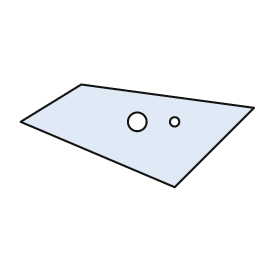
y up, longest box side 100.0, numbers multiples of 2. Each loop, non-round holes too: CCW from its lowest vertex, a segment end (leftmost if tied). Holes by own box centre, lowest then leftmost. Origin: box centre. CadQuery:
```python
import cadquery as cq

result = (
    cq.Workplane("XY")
    .moveTo(16.0, -22.0)
    .lineTo(50.0, 12.0)
    .lineTo(-24.0, 22.0)
    .lineTo(-50.0, 6.0)
    .close()
    .moveTo(0.0, 6.0)
    .circle(4.0)
    .moveTo(16.0, 6.0)
    .circle(2.0)
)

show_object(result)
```